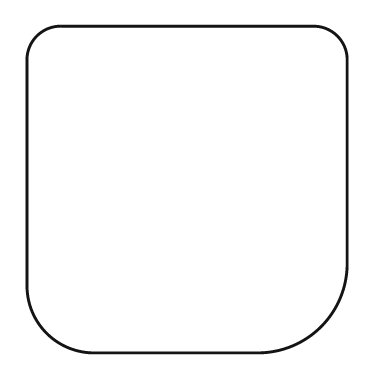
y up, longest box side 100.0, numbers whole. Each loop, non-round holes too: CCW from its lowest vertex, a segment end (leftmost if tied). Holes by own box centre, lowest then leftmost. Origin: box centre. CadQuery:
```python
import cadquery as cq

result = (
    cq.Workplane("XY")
    .moveTo(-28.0, -50.0)
    .lineTo(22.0, -50.0)
    .threePointArc((41.0, -42.0), (49.0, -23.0))
    .lineTo(49.0, 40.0)
    .threePointArc((46.0, 47.0), (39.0, 50.0))
    .lineTo(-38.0, 50.0)
    .threePointArc((-46.0, 47.0), (-49.0, 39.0))
    .lineTo(-49.0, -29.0)
    .threePointArc((-43.0, -44.0), (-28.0, -50.0))
    .close()
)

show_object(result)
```